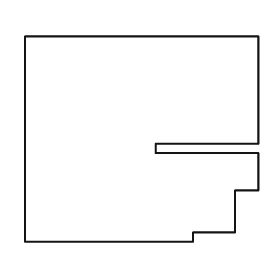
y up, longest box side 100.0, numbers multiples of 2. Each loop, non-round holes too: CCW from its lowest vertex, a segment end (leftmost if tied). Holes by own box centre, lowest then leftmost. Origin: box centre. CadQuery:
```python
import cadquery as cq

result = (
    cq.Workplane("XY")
    .moveTo(-50.0, -44.0)
    .lineTo(22.0, -44.0)
    .lineTo(22.0, -40.0)
    .lineTo(40.0, -40.0)
    .lineTo(40.0, -22.0)
    .lineTo(50.0, -22.0)
    .lineTo(50.0, -6.0)
    .lineTo(6.0, -6.0)
    .lineTo(6.0, -2.0)
    .lineTo(50.0, -2.0)
    .lineTo(50.0, 44.0)
    .lineTo(-50.0, 44.0)
    .close()
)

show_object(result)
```